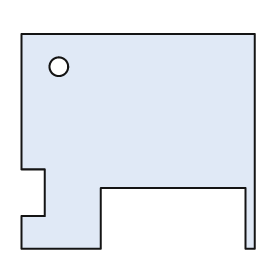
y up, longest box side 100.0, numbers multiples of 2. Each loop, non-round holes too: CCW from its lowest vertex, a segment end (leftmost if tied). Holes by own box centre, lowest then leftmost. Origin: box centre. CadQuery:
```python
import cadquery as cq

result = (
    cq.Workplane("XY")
    .moveTo(-50.0, -46.0)
    .lineTo(-16.0, -46.0)
    .lineTo(-16.0, -20.0)
    .lineTo(46.0, -20.0)
    .lineTo(46.0, -46.0)
    .lineTo(50.0, -46.0)
    .lineTo(50.0, 46.0)
    .lineTo(-50.0, 46.0)
    .lineTo(-50.0, -12.0)
    .lineTo(-40.0, -12.0)
    .lineTo(-40.0, -32.0)
    .lineTo(-50.0, -32.0)
    .close()
    .moveTo(-34.0, 32.0)
    .circle(4.0)
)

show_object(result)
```